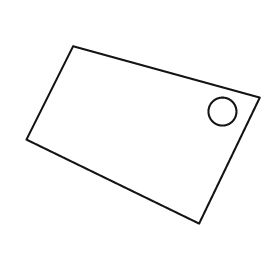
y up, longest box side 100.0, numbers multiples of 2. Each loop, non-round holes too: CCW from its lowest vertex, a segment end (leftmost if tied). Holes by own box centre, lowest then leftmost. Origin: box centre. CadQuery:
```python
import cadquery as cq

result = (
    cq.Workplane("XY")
    .moveTo(24.0, -38.0)
    .lineTo(50.0, 16.0)
    .lineTo(-30.0, 38.0)
    .lineTo(-50.0, -2.0)
    .close()
    .moveTo(34.0, 10.0)
    .circle(6.0)
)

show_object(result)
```